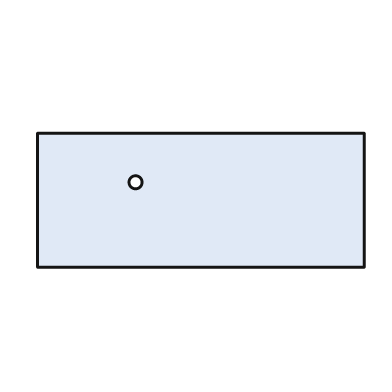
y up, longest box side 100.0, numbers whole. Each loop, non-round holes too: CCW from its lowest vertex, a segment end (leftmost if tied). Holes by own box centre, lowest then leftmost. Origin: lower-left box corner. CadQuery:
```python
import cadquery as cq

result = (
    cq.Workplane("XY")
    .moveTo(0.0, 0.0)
    .lineTo(100.0, 0.0)
    .lineTo(100.0, 41.0)
    .lineTo(0.0, 41.0)
    .close()
    .moveTo(30.0, 26.0)
    .circle(2.0)
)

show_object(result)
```